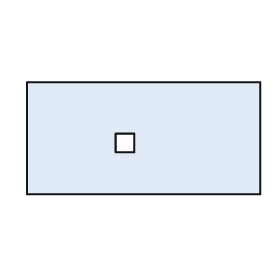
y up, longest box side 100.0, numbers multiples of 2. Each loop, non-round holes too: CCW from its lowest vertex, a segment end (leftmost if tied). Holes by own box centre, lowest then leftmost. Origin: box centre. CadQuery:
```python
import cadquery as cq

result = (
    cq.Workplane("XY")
    .moveTo(-50.0, -24.0)
    .lineTo(50.0, -24.0)
    .lineTo(50.0, 24.0)
    .lineTo(-50.0, 24.0)
    .close()
    .moveTo(-12.0, -6.0)
    .lineTo(-4.0, -6.0)
    .lineTo(-4.0, 2.0)
    .lineTo(-12.0, 2.0)
    .close()
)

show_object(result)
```